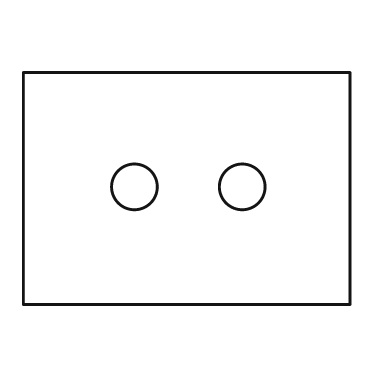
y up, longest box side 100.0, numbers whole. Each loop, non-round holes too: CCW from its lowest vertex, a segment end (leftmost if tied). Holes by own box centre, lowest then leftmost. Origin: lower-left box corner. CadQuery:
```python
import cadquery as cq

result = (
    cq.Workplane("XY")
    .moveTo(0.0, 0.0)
    .lineTo(100.0, 0.0)
    .lineTo(100.0, 71.0)
    .lineTo(0.0, 71.0)
    .close()
    .moveTo(34.0, 36.0)
    .circle(7.0)
    .moveTo(67.0, 36.0)
    .circle(7.0)
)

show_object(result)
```